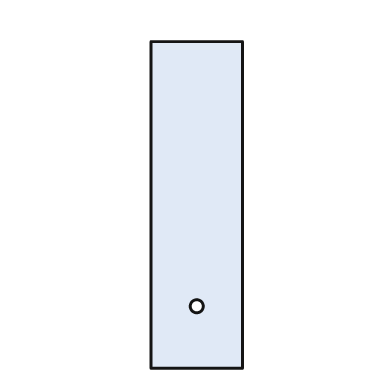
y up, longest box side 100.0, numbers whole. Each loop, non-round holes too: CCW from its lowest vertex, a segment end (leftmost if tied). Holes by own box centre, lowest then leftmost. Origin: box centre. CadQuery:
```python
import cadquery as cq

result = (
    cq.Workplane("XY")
    .moveTo(-14.0, -50.0)
    .lineTo(14.0, -50.0)
    .lineTo(14.0, 50.0)
    .lineTo(-14.0, 50.0)
    .close()
    .moveTo(0.0, -31.0)
    .circle(2.0)
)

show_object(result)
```